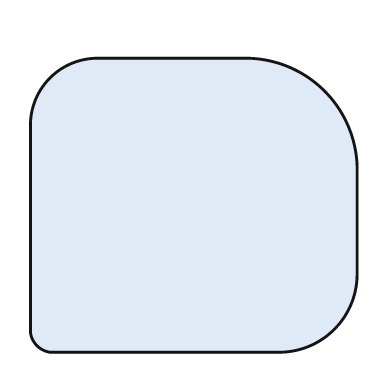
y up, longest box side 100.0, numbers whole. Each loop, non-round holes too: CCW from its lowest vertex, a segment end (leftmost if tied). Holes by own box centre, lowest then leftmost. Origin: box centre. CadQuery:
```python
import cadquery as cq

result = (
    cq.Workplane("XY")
    .moveTo(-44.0, -45.0)
    .lineTo(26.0, -45.0)
    .threePointArc((43.0, -38.0), (50.0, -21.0))
    .lineTo(50.0, 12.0)
    .threePointArc((40.0, 35.0), (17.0, 45.0))
    .lineTo(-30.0, 45.0)
    .threePointArc((-44.0, 39.0), (-50.0, 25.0))
    .lineTo(-50.0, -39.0)
    .threePointArc((-48.0, -43.0), (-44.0, -45.0))
    .close()
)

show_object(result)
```